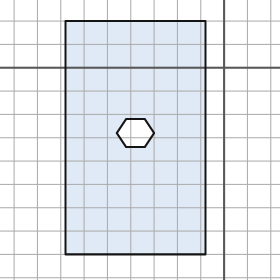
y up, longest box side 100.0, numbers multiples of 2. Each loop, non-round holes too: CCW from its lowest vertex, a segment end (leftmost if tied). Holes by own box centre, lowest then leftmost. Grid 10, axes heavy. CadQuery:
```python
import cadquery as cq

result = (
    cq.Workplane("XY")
    .moveTo(-68.0, -80.0)
    .lineTo(-8.0, -80.0)
    .lineTo(-8.0, 20.0)
    .lineTo(-68.0, 20.0)
    .close()
    .moveTo(-42.0, -34.0)
    .lineTo(-34.0, -34.0)
    .lineTo(-30.0, -28.0)
    .lineTo(-34.0, -22.0)
    .lineTo(-42.0, -22.0)
    .lineTo(-46.0, -28.0)
    .close()
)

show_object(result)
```